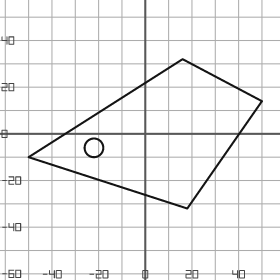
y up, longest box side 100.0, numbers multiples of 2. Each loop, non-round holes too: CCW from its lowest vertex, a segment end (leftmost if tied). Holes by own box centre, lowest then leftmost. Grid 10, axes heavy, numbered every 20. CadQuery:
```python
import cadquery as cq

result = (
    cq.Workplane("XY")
    .moveTo(18.0, -32.0)
    .lineTo(50.0, 14.0)
    .lineTo(16.0, 32.0)
    .lineTo(-50.0, -10.0)
    .close()
    .moveTo(-22.0, -6.0)
    .circle(4.0)
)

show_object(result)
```